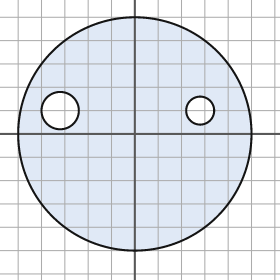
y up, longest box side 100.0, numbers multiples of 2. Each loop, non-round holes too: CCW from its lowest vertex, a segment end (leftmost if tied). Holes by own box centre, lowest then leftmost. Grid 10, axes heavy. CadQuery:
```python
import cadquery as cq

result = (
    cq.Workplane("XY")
    .moveTo(0.0, 0.0)
    .circle(50.0)
    .moveTo(-32.0, 10.0)
    .circle(8.0)
    .moveTo(28.0, 10.0)
    .circle(6.0)
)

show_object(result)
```